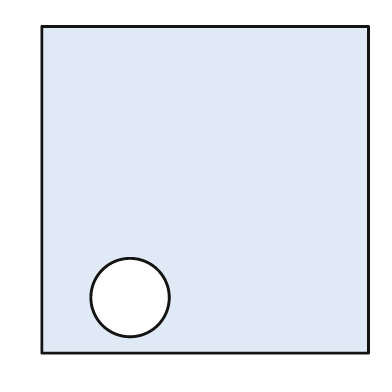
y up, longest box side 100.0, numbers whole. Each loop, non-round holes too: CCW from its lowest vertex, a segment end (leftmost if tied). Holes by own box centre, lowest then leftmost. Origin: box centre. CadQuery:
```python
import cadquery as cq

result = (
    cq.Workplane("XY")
    .moveTo(-50.0, -50.0)
    .lineTo(50.0, -50.0)
    .lineTo(50.0, 50.0)
    .lineTo(-50.0, 50.0)
    .close()
    .moveTo(-23.0, -33.0)
    .circle(12.0)
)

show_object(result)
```